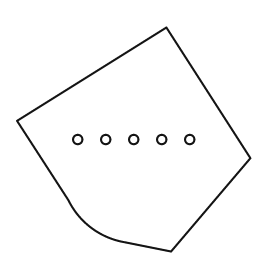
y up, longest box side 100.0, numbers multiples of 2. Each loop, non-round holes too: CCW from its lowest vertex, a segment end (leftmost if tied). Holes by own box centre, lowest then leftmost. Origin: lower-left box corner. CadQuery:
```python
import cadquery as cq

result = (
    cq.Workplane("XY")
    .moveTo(66.0, 0.0)
    .lineTo(100.0, 40.0)
    .lineTo(64.0, 96.0)
    .lineTo(0.0, 56.0)
    .lineTo(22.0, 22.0)
    .threePointArc((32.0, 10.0), (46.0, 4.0))
    .close()
    .moveTo(26.0, 48.0)
    .circle(2.0)
    .moveTo(38.0, 48.0)
    .circle(2.0)
    .moveTo(50.0, 48.0)
    .circle(2.0)
    .moveTo(62.0, 48.0)
    .circle(2.0)
    .moveTo(74.0, 48.0)
    .circle(2.0)
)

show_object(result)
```